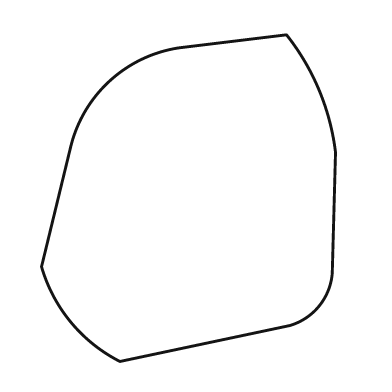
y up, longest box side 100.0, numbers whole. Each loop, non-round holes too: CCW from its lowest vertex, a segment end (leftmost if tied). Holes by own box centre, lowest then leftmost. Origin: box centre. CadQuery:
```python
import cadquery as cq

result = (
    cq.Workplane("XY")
    .moveTo(-21.0, -50.0)
    .lineTo(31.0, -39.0)
    .threePointArc((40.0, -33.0), (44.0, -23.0))
    .lineTo(45.0, 14.0)
    .threePointArc((40.0, 33.0), (30.0, 50.0))
    .lineTo(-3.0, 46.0)
    .threePointArc((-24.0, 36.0), (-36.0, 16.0))
    .lineTo(-45.0, -21.0)
    .threePointArc((-36.0, -38.0), (-21.0, -50.0))
    .close()
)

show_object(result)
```